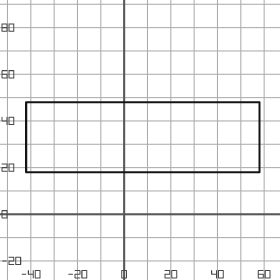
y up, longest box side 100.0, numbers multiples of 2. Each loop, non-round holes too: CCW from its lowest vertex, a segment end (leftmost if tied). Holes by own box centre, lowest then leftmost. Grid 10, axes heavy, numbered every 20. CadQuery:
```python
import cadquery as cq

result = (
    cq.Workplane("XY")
    .moveTo(-42.0, 18.0)
    .lineTo(58.0, 18.0)
    .lineTo(58.0, 48.0)
    .lineTo(-42.0, 48.0)
    .close()
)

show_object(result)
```